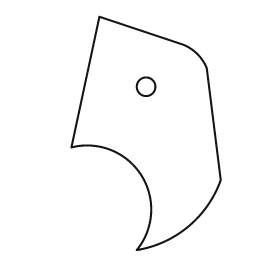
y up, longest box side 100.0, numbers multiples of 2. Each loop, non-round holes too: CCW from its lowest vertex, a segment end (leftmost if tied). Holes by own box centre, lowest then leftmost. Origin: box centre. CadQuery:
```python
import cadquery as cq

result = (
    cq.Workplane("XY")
    .moveTo(-4.0, -50.0)
    .threePointArc((18.0, -40.0), (32.0, -20.0))
    .lineTo(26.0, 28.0)
    .threePointArc((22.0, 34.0), (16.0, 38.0))
    .lineTo(-20.0, 50.0)
    .lineTo(-32.0, -6.0)
    .threePointArc((-2.0, -18.0), (-4.0, -50.0))
    .close()
    .moveTo(0.0, 20.0)
    .circle(4.0)
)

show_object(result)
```